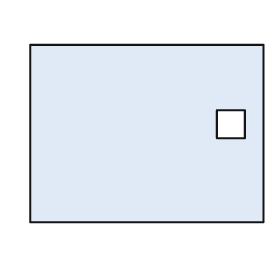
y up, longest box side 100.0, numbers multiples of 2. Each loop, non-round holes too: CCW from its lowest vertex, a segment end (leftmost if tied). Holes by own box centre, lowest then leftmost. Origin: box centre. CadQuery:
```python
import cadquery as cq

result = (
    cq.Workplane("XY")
    .moveTo(-50.0, -38.0)
    .lineTo(50.0, -38.0)
    .lineTo(50.0, 38.0)
    .lineTo(-50.0, 38.0)
    .close()
    .moveTo(30.0, -2.0)
    .lineTo(42.0, -2.0)
    .lineTo(42.0, 10.0)
    .lineTo(30.0, 10.0)
    .close()
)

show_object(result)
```